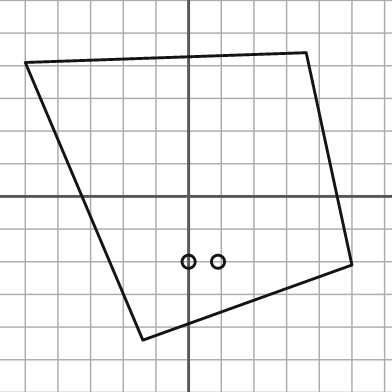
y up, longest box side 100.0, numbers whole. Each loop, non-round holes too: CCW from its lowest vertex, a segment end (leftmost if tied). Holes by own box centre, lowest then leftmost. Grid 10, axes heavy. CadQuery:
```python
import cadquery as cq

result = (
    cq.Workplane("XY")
    .moveTo(-14.0, -44.0)
    .lineTo(50.0, -21.0)
    .lineTo(36.0, 44.0)
    .lineTo(-50.0, 41.0)
    .close()
    .moveTo(0.0, -20.0)
    .circle(2.0)
    .moveTo(9.0, -20.0)
    .circle(2.0)
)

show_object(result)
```